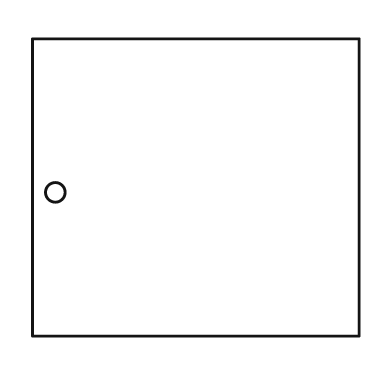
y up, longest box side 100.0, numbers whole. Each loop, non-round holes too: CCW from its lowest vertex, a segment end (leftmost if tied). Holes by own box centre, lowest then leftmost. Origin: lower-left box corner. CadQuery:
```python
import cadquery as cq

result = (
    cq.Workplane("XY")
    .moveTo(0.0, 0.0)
    .lineTo(100.0, 0.0)
    .lineTo(100.0, 91.0)
    .lineTo(0.0, 91.0)
    .close()
    .moveTo(7.0, 44.0)
    .circle(3.0)
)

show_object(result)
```